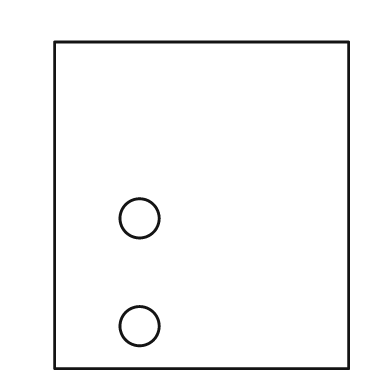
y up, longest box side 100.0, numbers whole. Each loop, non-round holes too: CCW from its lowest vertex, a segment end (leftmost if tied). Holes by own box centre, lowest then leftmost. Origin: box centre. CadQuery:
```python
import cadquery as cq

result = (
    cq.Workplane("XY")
    .moveTo(-45.0, -50.0)
    .lineTo(45.0, -50.0)
    .lineTo(45.0, 50.0)
    .lineTo(-45.0, 50.0)
    .close()
    .moveTo(-19.0, -37.0)
    .circle(6.0)
    .moveTo(-19.0, -4.0)
    .circle(6.0)
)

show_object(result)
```